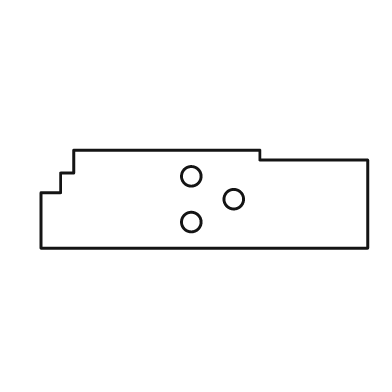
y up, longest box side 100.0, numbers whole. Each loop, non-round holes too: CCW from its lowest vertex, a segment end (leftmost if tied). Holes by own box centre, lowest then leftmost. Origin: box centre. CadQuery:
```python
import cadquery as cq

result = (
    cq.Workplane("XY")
    .moveTo(-50.0, -15.0)
    .lineTo(50.0, -15.0)
    .lineTo(50.0, 12.0)
    .lineTo(17.0, 12.0)
    .lineTo(17.0, 15.0)
    .lineTo(-40.0, 15.0)
    .lineTo(-40.0, 8.0)
    .lineTo(-44.0, 8.0)
    .lineTo(-44.0, 2.0)
    .lineTo(-50.0, 2.0)
    .close()
    .moveTo(-4.0, -7.0)
    .circle(3.0)
    .moveTo(9.0, 0.0)
    .circle(3.0)
    .moveTo(-4.0, 7.0)
    .circle(3.0)
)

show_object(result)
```